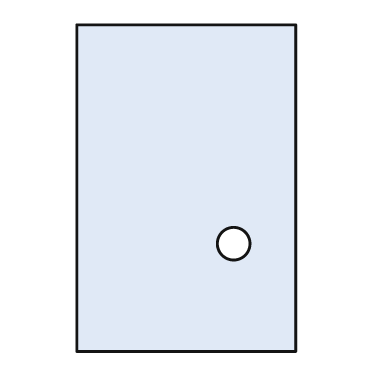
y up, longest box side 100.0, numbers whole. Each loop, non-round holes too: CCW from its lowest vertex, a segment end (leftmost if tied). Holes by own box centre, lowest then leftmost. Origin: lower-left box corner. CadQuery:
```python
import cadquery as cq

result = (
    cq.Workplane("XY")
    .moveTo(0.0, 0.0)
    .lineTo(67.0, 0.0)
    .lineTo(67.0, 100.0)
    .lineTo(0.0, 100.0)
    .close()
    .moveTo(48.0, 33.0)
    .circle(5.0)
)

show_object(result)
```